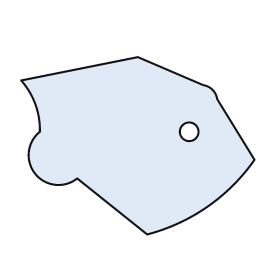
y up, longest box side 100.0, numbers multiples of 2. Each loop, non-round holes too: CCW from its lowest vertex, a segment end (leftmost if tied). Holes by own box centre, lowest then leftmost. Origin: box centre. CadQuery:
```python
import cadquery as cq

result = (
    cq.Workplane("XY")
    .moveTo(4.0, -38.0)
    .threePointArc((30.0, -26.0), (50.0, -6.0))
    .lineTo(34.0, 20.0)
    .threePointArc((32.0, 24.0), (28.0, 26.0))
    .lineTo(0.0, 38.0)
    .lineTo(-50.0, 28.0)
    .threePointArc((-44.0, 18.0), (-42.0, 6.0))
    .threePointArc((-44.0, -12.0), (-26.0, -14.0))
    .close()
    .moveTo(22.0, 6.0)
    .circle(4.0)
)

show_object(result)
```